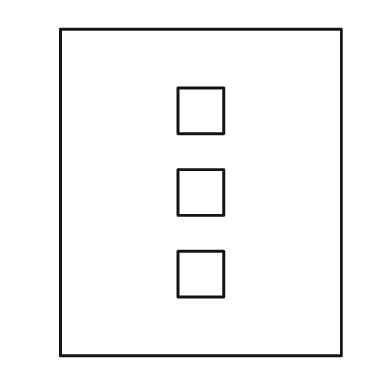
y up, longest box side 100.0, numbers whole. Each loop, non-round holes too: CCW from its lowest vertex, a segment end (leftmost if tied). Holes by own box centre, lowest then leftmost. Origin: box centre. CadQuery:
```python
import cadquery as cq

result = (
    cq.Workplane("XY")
    .moveTo(-43.0, -50.0)
    .lineTo(43.0, -50.0)
    .lineTo(43.0, 50.0)
    .lineTo(-43.0, 50.0)
    .close()
    .moveTo(-7.0, -32.0)
    .lineTo(7.0, -32.0)
    .lineTo(7.0, -18.0)
    .lineTo(-7.0, -18.0)
    .close()
    .moveTo(-7.0, -7.0)
    .lineTo(7.0, -7.0)
    .lineTo(7.0, 7.0)
    .lineTo(-7.0, 7.0)
    .close()
    .moveTo(-7.0, 18.0)
    .lineTo(7.0, 18.0)
    .lineTo(7.0, 32.0)
    .lineTo(-7.0, 32.0)
    .close()
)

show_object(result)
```